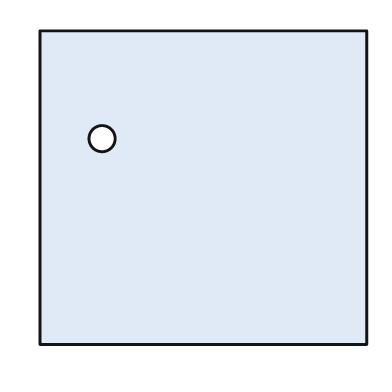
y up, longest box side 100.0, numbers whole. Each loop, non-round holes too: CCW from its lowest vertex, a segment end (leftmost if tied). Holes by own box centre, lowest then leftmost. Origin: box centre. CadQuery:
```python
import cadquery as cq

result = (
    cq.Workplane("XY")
    .moveTo(-50.0, -48.0)
    .lineTo(50.0, -48.0)
    .lineTo(50.0, 48.0)
    .lineTo(-50.0, 48.0)
    .close()
    .moveTo(-31.0, 15.0)
    .circle(4.0)
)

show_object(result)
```